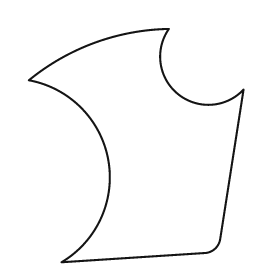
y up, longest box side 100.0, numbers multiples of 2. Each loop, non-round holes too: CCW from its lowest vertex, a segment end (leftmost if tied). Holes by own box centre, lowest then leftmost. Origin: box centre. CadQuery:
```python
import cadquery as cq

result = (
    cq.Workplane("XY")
    .moveTo(-32.0, -50.0)
    .lineTo(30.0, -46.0)
    .threePointArc((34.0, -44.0), (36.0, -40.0))
    .lineTo(46.0, 24.0)
    .threePointArc((18.0, 22.0), (14.0, 50.0))
    .threePointArc((-18.0, 44.0), (-46.0, 28.0))
    .threePointArc((-12.0, -6.0), (-32.0, -50.0))
    .close()
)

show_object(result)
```